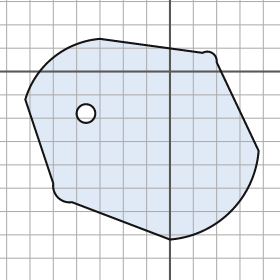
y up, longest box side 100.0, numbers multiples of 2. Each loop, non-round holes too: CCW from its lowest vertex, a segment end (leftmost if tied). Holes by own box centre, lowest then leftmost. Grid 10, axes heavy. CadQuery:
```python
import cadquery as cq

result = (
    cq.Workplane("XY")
    .moveTo(0.0, -72.0)
    .threePointArc((26.0, -60.0), (38.0, -34.0))
    .lineTo(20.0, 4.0)
    .threePointArc((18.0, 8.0), (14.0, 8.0))
    .lineTo(-30.0, 14.0)
    .threePointArc((-50.0, 6.0), (-62.0, -12.0))
    .lineTo(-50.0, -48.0)
    .threePointArc((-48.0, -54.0), (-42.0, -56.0))
    .close()
    .moveTo(-36.0, -18.0)
    .circle(4.0)
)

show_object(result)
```